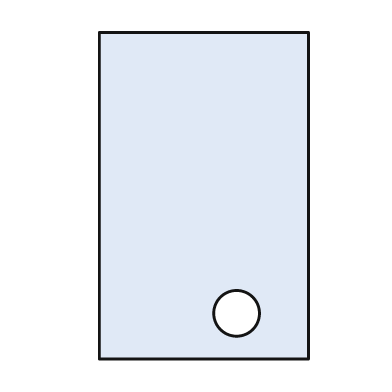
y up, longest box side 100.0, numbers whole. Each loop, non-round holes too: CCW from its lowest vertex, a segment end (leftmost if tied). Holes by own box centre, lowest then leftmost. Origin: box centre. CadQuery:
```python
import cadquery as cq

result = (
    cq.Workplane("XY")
    .moveTo(-32.0, -50.0)
    .lineTo(32.0, -50.0)
    .lineTo(32.0, 50.0)
    .lineTo(-32.0, 50.0)
    .close()
    .moveTo(10.0, -36.0)
    .circle(7.0)
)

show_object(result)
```